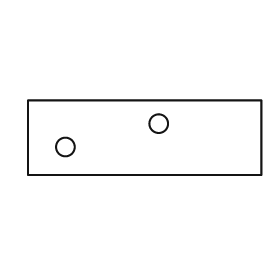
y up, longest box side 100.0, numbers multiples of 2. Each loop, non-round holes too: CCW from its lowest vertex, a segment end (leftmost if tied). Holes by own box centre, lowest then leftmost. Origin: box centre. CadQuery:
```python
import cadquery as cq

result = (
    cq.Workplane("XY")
    .moveTo(-50.0, -16.0)
    .lineTo(50.0, -16.0)
    .lineTo(50.0, 16.0)
    .lineTo(-50.0, 16.0)
    .close()
    .moveTo(-34.0, -4.0)
    .circle(4.0)
    .moveTo(6.0, 6.0)
    .circle(4.0)
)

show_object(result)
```